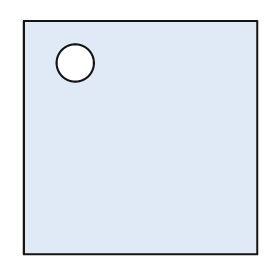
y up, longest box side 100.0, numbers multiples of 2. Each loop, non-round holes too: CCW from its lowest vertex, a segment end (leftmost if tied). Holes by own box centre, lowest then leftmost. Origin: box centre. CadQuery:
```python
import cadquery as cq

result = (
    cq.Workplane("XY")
    .moveTo(-50.0, -50.0)
    .lineTo(50.0, -50.0)
    .lineTo(50.0, 50.0)
    .lineTo(-50.0, 50.0)
    .close()
    .moveTo(-28.0, 32.0)
    .circle(8.0)
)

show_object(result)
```